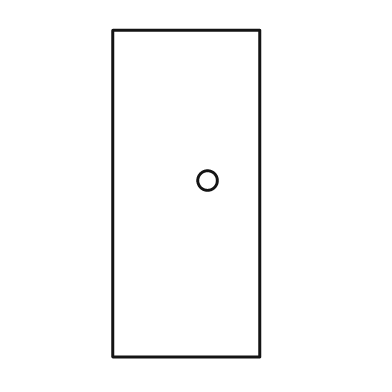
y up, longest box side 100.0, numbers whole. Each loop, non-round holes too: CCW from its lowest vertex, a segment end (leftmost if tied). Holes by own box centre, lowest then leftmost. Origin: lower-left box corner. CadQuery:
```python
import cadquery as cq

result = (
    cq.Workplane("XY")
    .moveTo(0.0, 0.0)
    .lineTo(45.0, 0.0)
    .lineTo(45.0, 100.0)
    .lineTo(0.0, 100.0)
    .close()
    .moveTo(29.0, 54.0)
    .circle(3.0)
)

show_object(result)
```